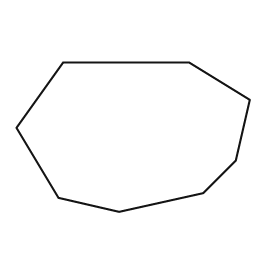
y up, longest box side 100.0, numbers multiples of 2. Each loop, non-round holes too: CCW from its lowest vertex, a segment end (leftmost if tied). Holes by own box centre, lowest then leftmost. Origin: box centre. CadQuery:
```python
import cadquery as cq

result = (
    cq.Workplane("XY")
    .moveTo(-6.0, -32.0)
    .lineTo(30.0, -24.0)
    .lineTo(44.0, -10.0)
    .lineTo(50.0, 16.0)
    .lineTo(24.0, 32.0)
    .lineTo(-30.0, 32.0)
    .lineTo(-50.0, 4.0)
    .lineTo(-32.0, -26.0)
    .close()
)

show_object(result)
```